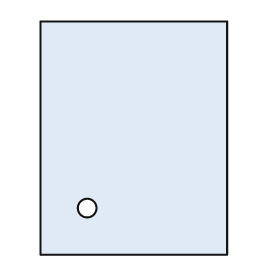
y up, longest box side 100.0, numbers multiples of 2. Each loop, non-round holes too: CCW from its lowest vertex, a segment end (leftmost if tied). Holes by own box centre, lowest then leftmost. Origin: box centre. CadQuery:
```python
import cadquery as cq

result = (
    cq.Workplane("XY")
    .moveTo(-40.0, -50.0)
    .lineTo(40.0, -50.0)
    .lineTo(40.0, 50.0)
    .lineTo(-40.0, 50.0)
    .close()
    .moveTo(-20.0, -30.0)
    .circle(4.0)
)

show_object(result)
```